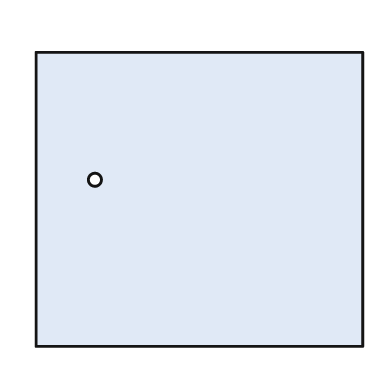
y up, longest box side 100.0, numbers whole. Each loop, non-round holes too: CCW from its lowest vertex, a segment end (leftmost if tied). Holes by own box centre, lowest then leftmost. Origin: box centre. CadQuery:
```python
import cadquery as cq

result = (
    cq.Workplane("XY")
    .moveTo(-50.0, -45.0)
    .lineTo(50.0, -45.0)
    .lineTo(50.0, 45.0)
    .lineTo(-50.0, 45.0)
    .close()
    .moveTo(-32.0, 6.0)
    .circle(2.0)
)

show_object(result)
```